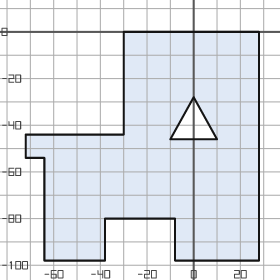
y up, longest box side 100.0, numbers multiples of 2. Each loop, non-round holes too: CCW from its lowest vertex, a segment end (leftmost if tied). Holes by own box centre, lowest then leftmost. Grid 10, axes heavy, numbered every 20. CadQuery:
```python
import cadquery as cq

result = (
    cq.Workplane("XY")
    .moveTo(-64.0, -98.0)
    .lineTo(-38.0, -98.0)
    .lineTo(-38.0, -80.0)
    .lineTo(-8.0, -80.0)
    .lineTo(-8.0, -98.0)
    .lineTo(28.0, -98.0)
    .lineTo(28.0, 0.0)
    .lineTo(-30.0, 0.0)
    .lineTo(-30.0, -44.0)
    .lineTo(-72.0, -44.0)
    .lineTo(-72.0, -54.0)
    .lineTo(-64.0, -54.0)
    .close()
    .moveTo(-10.0, -46.0)
    .lineTo(10.0, -46.0)
    .lineTo(0.0, -28.0)
    .close()
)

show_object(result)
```